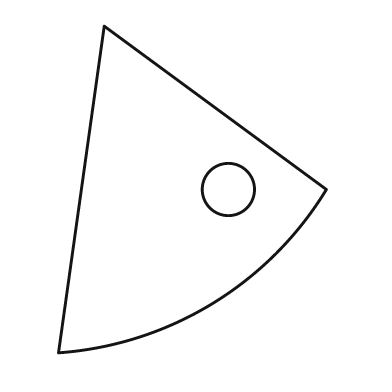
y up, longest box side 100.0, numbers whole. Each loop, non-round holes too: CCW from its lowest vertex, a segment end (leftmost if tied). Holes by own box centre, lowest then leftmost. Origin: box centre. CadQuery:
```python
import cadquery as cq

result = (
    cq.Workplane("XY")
    .moveTo(-41.0, -50.0)
    .threePointArc((6.0, -35.0), (41.0, 0.0))
    .lineTo(-27.0, 50.0)
    .close()
    .moveTo(11.0, 0.0)
    .circle(8.0)
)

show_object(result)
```